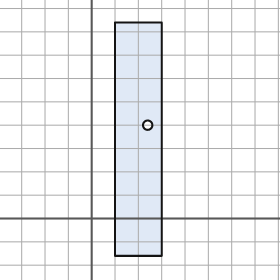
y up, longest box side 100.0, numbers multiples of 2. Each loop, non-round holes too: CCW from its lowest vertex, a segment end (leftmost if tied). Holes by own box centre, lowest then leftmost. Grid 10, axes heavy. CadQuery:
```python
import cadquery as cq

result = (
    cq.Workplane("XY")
    .moveTo(10.0, -16.0)
    .lineTo(30.0, -16.0)
    .lineTo(30.0, 84.0)
    .lineTo(10.0, 84.0)
    .close()
    .moveTo(24.0, 40.0)
    .circle(2.0)
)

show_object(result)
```